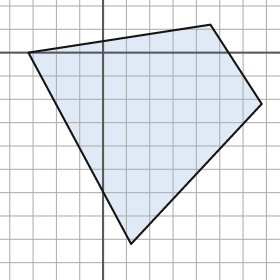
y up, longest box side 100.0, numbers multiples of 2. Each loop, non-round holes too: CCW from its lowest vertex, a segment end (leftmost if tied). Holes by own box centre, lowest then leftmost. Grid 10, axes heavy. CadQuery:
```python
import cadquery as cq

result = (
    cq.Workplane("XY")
    .moveTo(12.0, -82.0)
    .lineTo(68.0, -22.0)
    .lineTo(46.0, 12.0)
    .lineTo(-32.0, 0.0)
    .close()
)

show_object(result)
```